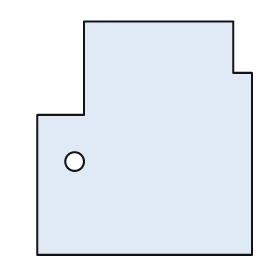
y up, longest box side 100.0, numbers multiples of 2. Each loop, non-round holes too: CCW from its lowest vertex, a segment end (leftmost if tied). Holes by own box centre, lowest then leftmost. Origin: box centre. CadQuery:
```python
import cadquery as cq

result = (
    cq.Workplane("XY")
    .moveTo(-46.0, -50.0)
    .lineTo(46.0, -50.0)
    .lineTo(46.0, 28.0)
    .lineTo(38.0, 28.0)
    .lineTo(38.0, 50.0)
    .lineTo(-26.0, 50.0)
    .lineTo(-26.0, 10.0)
    .lineTo(-46.0, 10.0)
    .close()
    .moveTo(-30.0, -10.0)
    .circle(4.0)
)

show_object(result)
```